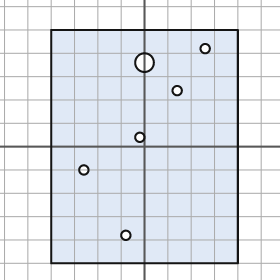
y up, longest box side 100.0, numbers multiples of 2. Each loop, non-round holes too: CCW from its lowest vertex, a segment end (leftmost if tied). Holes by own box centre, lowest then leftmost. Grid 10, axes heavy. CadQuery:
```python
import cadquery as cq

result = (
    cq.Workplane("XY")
    .moveTo(-40.0, -50.0)
    .lineTo(40.0, -50.0)
    .lineTo(40.0, 50.0)
    .lineTo(-40.0, 50.0)
    .close()
    .moveTo(-8.0, -38.0)
    .circle(2.0)
    .moveTo(-26.0, -10.0)
    .circle(2.0)
    .moveTo(-2.0, 4.0)
    .circle(2.0)
    .moveTo(14.0, 24.0)
    .circle(2.0)
    .moveTo(0.0, 36.0)
    .circle(4.0)
    .moveTo(26.0, 42.0)
    .circle(2.0)
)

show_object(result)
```